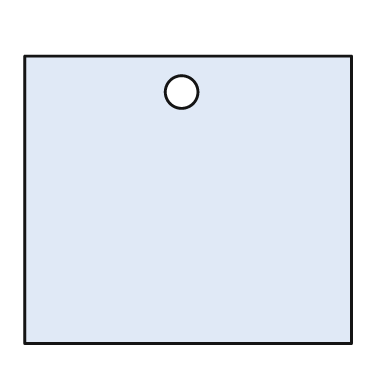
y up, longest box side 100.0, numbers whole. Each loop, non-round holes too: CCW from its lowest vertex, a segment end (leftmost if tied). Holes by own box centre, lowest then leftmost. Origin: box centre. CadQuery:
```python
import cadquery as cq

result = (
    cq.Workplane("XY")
    .moveTo(-50.0, -44.0)
    .lineTo(50.0, -44.0)
    .lineTo(50.0, 44.0)
    .lineTo(-50.0, 44.0)
    .close()
    .moveTo(-2.0, 33.0)
    .circle(5.0)
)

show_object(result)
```